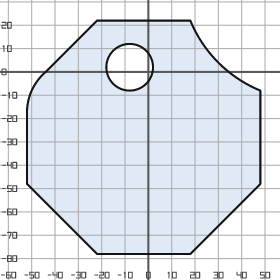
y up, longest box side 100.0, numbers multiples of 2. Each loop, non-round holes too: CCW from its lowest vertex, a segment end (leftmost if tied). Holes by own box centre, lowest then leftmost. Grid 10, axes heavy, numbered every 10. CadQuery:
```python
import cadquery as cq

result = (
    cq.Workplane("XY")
    .moveTo(-22.0, -78.0)
    .lineTo(18.0, -78.0)
    .lineTo(48.0, -48.0)
    .lineTo(48.0, -8.0)
    .threePointArc((30.0, 4.0), (18.0, 22.0))
    .lineTo(-22.0, 22.0)
    .lineTo(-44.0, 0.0)
    .threePointArc((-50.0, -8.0), (-52.0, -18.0))
    .lineTo(-52.0, -48.0)
    .close()
    .moveTo(-8.0, 2.0)
    .circle(10.0)
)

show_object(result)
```